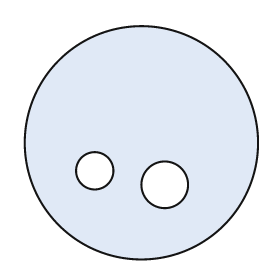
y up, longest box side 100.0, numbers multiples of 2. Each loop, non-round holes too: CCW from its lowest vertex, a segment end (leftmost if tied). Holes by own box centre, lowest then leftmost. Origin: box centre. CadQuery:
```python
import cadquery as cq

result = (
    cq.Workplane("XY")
    .moveTo(0.0, 0.0)
    .circle(50.0)
    .moveTo(10.0, -18.0)
    .circle(10.0)
    .moveTo(-20.0, -12.0)
    .circle(8.0)
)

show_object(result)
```